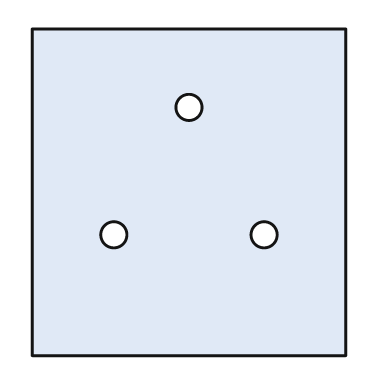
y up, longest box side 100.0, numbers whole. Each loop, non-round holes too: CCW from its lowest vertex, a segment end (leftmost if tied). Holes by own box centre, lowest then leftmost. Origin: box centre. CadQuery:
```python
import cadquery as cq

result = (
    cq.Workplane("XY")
    .moveTo(-48.0, -50.0)
    .lineTo(48.0, -50.0)
    .lineTo(48.0, 50.0)
    .lineTo(-48.0, 50.0)
    .close()
    .moveTo(-23.0, -13.0)
    .circle(4.0)
    .moveTo(23.0, -13.0)
    .circle(4.0)
    .moveTo(0.0, 26.0)
    .circle(4.0)
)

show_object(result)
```